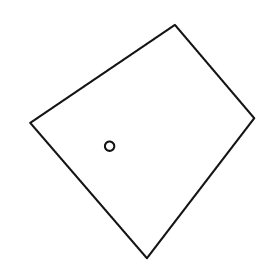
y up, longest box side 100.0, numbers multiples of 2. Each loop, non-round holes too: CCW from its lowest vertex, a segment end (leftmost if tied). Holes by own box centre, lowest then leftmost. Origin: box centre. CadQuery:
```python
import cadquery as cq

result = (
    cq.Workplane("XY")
    .moveTo(2.0, -50.0)
    .lineTo(48.0, 10.0)
    .lineTo(14.0, 50.0)
    .lineTo(-48.0, 8.0)
    .close()
    .moveTo(-14.0, -2.0)
    .circle(2.0)
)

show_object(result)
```